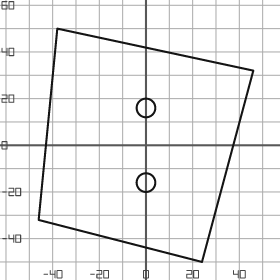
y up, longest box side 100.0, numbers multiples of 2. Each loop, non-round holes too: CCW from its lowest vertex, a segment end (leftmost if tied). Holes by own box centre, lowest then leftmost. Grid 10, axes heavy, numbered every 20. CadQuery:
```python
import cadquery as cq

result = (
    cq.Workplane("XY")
    .moveTo(24.0, -50.0)
    .lineTo(46.0, 32.0)
    .lineTo(-38.0, 50.0)
    .lineTo(-46.0, -32.0)
    .close()
    .moveTo(0.0, -16.0)
    .circle(4.0)
    .moveTo(0.0, 16.0)
    .circle(4.0)
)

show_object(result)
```